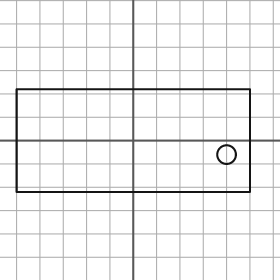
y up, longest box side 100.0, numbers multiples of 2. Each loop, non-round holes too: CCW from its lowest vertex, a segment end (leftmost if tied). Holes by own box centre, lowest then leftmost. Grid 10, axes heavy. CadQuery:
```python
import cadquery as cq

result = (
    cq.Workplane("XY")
    .moveTo(-50.0, -22.0)
    .lineTo(50.0, -22.0)
    .lineTo(50.0, 22.0)
    .lineTo(-50.0, 22.0)
    .close()
    .moveTo(40.0, -6.0)
    .circle(4.0)
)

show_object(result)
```